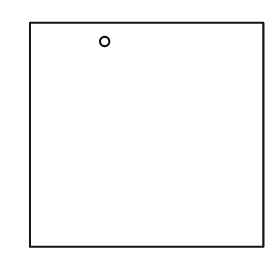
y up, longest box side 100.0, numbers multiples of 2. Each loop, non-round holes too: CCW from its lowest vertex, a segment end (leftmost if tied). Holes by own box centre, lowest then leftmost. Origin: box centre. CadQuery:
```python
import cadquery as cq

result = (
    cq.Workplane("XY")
    .moveTo(-50.0, -48.0)
    .lineTo(50.0, -48.0)
    .lineTo(50.0, 48.0)
    .lineTo(-50.0, 48.0)
    .close()
    .moveTo(-18.0, 40.0)
    .circle(2.0)
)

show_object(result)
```